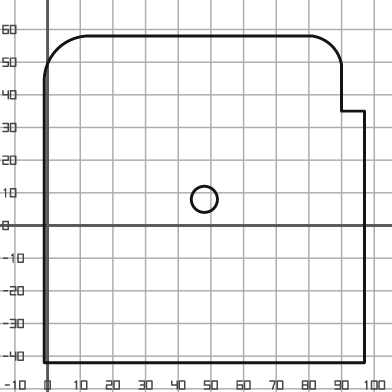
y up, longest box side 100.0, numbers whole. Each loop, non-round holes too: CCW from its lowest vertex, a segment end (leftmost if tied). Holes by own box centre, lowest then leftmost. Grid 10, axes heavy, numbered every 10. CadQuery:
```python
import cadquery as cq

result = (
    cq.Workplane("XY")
    .moveTo(-1.0, -42.0)
    .lineTo(97.0, -42.0)
    .lineTo(97.0, 35.0)
    .lineTo(90.0, 35.0)
    .lineTo(90.0, 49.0)
    .threePointArc((87.0, 55.0), (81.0, 58.0))
    .lineTo(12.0, 58.0)
    .threePointArc((3.0, 54.0), (-1.0, 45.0))
    .close()
    .moveTo(48.0, 8.0)
    .circle(4.0)
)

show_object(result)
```